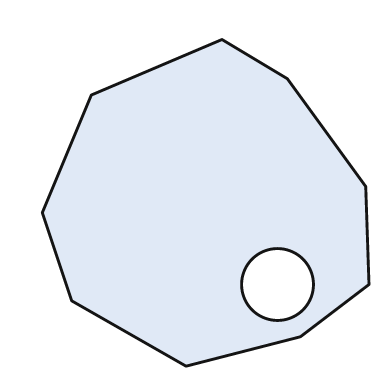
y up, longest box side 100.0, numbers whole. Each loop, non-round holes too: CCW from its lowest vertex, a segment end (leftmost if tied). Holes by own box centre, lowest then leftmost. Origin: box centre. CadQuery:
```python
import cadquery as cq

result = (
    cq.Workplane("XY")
    .moveTo(-6.0, -50.0)
    .lineTo(29.0, -41.0)
    .lineTo(50.0, -25.0)
    .lineTo(49.0, 5.0)
    .lineTo(25.0, 38.0)
    .lineTo(5.0, 50.0)
    .lineTo(-35.0, 33.0)
    .lineTo(-50.0, -3.0)
    .lineTo(-41.0, -30.0)
    .close()
    .moveTo(22.0, -25.0)
    .circle(11.0)
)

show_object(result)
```